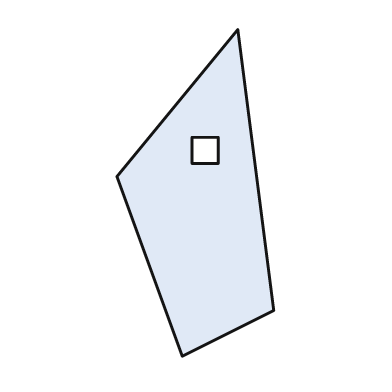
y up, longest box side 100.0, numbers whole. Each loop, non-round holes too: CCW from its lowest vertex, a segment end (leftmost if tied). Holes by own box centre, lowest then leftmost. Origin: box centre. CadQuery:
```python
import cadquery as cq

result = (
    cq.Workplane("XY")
    .moveTo(-4.0, -50.0)
    .lineTo(24.0, -36.0)
    .lineTo(13.0, 50.0)
    .lineTo(-24.0, 5.0)
    .close()
    .moveTo(-1.0, 9.0)
    .lineTo(7.0, 9.0)
    .lineTo(7.0, 17.0)
    .lineTo(-1.0, 17.0)
    .close()
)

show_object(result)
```